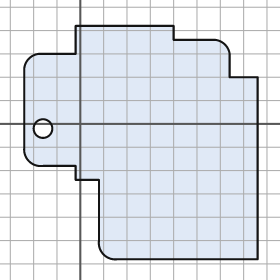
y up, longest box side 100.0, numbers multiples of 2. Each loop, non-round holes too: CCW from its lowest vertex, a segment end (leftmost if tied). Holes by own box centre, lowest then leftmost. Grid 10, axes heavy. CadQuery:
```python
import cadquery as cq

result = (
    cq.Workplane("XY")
    .moveTo(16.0, -58.0)
    .lineTo(76.0, -58.0)
    .lineTo(76.0, 20.0)
    .lineTo(64.0, 20.0)
    .lineTo(64.0, 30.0)
    .threePointArc((62.0, 34.0), (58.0, 36.0))
    .lineTo(40.0, 36.0)
    .lineTo(40.0, 42.0)
    .lineTo(-2.0, 42.0)
    .lineTo(-2.0, 30.0)
    .lineTo(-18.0, 30.0)
    .threePointArc((-22.0, 28.0), (-24.0, 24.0))
    .lineTo(-24.0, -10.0)
    .threePointArc((-22.0, -16.0), (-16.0, -18.0))
    .lineTo(-2.0, -18.0)
    .lineTo(-2.0, -24.0)
    .lineTo(8.0, -24.0)
    .lineTo(8.0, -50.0)
    .threePointArc((10.0, -56.0), (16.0, -58.0))
    .close()
    .moveTo(-16.0, -2.0)
    .circle(4.0)
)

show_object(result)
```